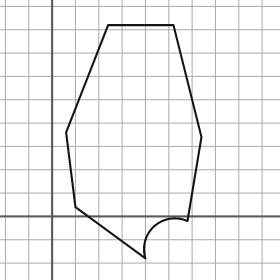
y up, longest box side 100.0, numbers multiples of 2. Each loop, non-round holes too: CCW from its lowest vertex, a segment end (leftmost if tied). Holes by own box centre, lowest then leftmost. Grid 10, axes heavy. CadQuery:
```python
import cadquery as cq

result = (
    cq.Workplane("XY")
    .moveTo(40.0, -18.0)
    .threePointArc((44.0, -4.0), (58.0, -2.0))
    .lineTo(64.0, 34.0)
    .lineTo(52.0, 82.0)
    .lineTo(24.0, 82.0)
    .lineTo(6.0, 36.0)
    .lineTo(10.0, 4.0)
    .close()
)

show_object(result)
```